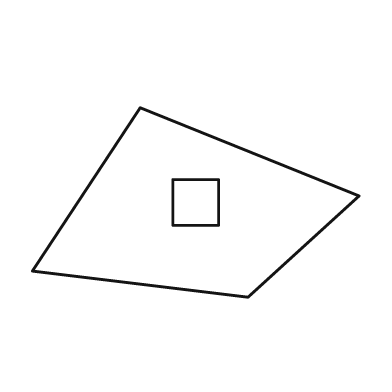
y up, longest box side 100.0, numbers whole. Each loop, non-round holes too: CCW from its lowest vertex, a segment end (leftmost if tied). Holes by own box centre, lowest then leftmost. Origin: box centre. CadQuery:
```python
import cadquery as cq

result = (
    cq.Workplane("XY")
    .moveTo(16.0, -29.0)
    .lineTo(50.0, 2.0)
    .lineTo(-17.0, 29.0)
    .lineTo(-50.0, -21.0)
    .close()
    .moveTo(-7.0, -7.0)
    .lineTo(7.0, -7.0)
    .lineTo(7.0, 7.0)
    .lineTo(-7.0, 7.0)
    .close()
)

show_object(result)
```